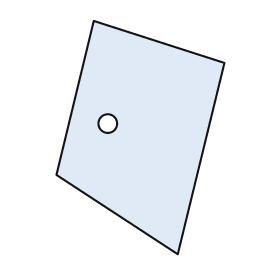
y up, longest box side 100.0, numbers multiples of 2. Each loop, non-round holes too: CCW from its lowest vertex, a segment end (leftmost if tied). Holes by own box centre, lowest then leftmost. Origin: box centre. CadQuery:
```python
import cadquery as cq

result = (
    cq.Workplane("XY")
    .moveTo(16.0, -50.0)
    .lineTo(36.0, 32.0)
    .lineTo(-20.0, 50.0)
    .lineTo(-36.0, -16.0)
    .close()
    .moveTo(-14.0, 6.0)
    .circle(4.0)
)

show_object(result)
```